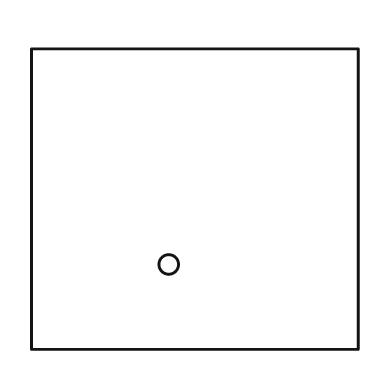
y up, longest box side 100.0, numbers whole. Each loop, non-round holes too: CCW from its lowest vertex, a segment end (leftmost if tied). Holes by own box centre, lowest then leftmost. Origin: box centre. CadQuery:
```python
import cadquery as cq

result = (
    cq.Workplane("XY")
    .moveTo(-50.0, -46.0)
    .lineTo(50.0, -46.0)
    .lineTo(50.0, 46.0)
    .lineTo(-50.0, 46.0)
    .close()
    .moveTo(-8.0, -20.0)
    .circle(3.0)
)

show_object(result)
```